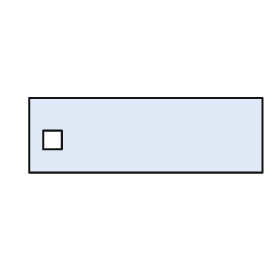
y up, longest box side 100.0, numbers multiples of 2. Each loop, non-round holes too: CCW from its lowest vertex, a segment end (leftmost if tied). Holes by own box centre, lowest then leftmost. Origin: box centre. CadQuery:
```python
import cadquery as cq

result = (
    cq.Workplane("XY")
    .moveTo(-50.0, -16.0)
    .lineTo(50.0, -16.0)
    .lineTo(50.0, 16.0)
    .lineTo(-50.0, 16.0)
    .close()
    .moveTo(-44.0, -6.0)
    .lineTo(-36.0, -6.0)
    .lineTo(-36.0, 2.0)
    .lineTo(-44.0, 2.0)
    .close()
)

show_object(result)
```